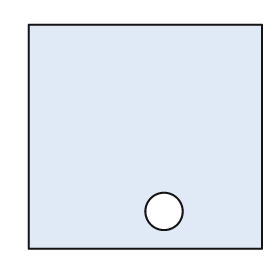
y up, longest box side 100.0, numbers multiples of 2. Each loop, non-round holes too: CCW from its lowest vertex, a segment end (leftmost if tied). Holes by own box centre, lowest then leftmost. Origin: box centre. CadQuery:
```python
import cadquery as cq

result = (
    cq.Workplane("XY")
    .moveTo(-50.0, -48.0)
    .lineTo(50.0, -48.0)
    .lineTo(50.0, 48.0)
    .lineTo(-50.0, 48.0)
    .close()
    .moveTo(8.0, -32.0)
    .circle(8.0)
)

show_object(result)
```